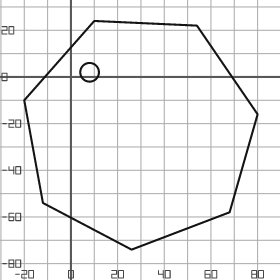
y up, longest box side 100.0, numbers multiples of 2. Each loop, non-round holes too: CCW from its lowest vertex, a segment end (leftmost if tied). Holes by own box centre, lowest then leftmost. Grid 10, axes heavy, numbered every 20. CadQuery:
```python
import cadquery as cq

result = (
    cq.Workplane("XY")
    .moveTo(26.0, -74.0)
    .lineTo(68.0, -58.0)
    .lineTo(80.0, -16.0)
    .lineTo(54.0, 22.0)
    .lineTo(10.0, 24.0)
    .lineTo(-20.0, -10.0)
    .lineTo(-12.0, -54.0)
    .close()
    .moveTo(8.0, 2.0)
    .circle(4.0)
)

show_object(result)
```